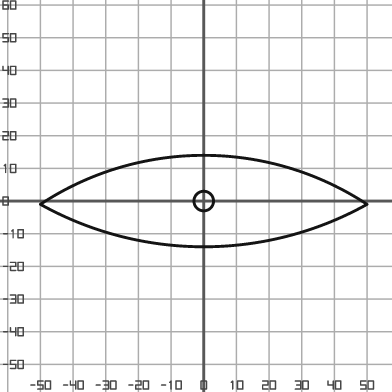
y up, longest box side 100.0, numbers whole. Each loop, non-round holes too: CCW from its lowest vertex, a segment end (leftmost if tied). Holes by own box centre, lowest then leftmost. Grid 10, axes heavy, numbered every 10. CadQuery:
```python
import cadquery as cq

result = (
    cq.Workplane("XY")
    .moveTo(-50.0, -1.0)
    .threePointArc((0.0, -14.0), (50.0, -1.0))
    .threePointArc((0.0, 14.0), (-50.0, -1.0))
    .close()
    .moveTo(0.0, 0.0)
    .circle(3.0)
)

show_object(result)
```